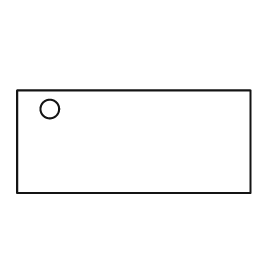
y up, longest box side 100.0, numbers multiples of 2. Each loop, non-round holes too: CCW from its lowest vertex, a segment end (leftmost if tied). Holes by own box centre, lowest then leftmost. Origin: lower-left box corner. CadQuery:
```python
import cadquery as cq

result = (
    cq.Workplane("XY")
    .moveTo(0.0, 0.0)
    .lineTo(100.0, 0.0)
    .lineTo(100.0, 44.0)
    .lineTo(0.0, 44.0)
    .close()
    .moveTo(14.0, 36.0)
    .circle(4.0)
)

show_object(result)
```